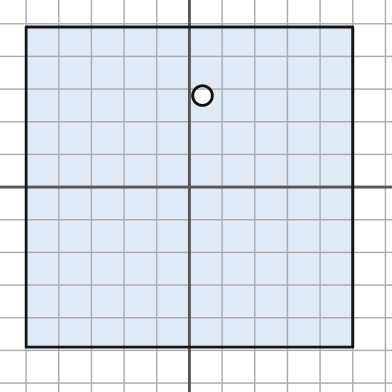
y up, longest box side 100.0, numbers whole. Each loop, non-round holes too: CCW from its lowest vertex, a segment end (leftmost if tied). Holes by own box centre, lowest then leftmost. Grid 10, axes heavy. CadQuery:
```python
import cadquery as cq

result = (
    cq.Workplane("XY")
    .moveTo(-50.0, -49.0)
    .lineTo(50.0, -49.0)
    .lineTo(50.0, 49.0)
    .lineTo(-50.0, 49.0)
    .close()
    .moveTo(4.0, 28.0)
    .circle(3.0)
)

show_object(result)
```